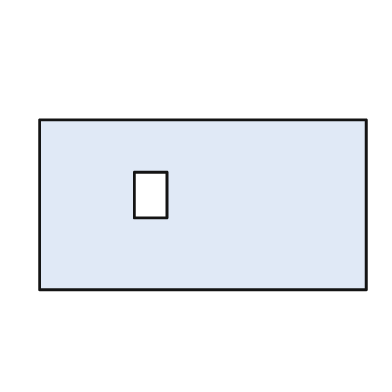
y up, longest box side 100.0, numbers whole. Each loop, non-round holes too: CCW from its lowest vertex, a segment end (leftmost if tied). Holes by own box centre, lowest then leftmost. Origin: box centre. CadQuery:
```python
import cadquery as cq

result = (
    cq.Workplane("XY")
    .moveTo(-50.0, -26.0)
    .lineTo(50.0, -26.0)
    .lineTo(50.0, 26.0)
    .lineTo(-50.0, 26.0)
    .close()
    .moveTo(-21.0, -4.0)
    .lineTo(-11.0, -4.0)
    .lineTo(-11.0, 10.0)
    .lineTo(-21.0, 10.0)
    .close()
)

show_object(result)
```